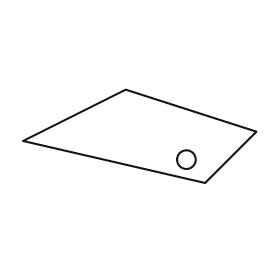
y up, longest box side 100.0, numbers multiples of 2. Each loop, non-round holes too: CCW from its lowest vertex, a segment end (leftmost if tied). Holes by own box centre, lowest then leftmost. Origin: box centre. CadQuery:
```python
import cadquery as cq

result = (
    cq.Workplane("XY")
    .moveTo(28.0, -20.0)
    .lineTo(50.0, 2.0)
    .lineTo(-6.0, 20.0)
    .lineTo(-50.0, -2.0)
    .close()
    .moveTo(20.0, -10.0)
    .circle(4.0)
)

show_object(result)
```